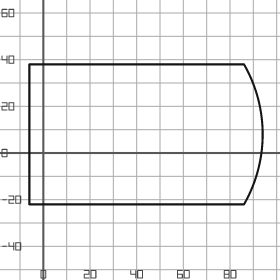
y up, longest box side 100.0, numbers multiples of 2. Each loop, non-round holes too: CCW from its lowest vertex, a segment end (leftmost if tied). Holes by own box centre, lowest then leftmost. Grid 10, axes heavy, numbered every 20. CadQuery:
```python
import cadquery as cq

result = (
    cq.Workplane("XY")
    .moveTo(-6.0, -22.0)
    .lineTo(86.0, -22.0)
    .threePointArc((94.0, 8.0), (86.0, 38.0))
    .lineTo(-6.0, 38.0)
    .close()
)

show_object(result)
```